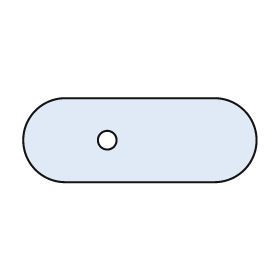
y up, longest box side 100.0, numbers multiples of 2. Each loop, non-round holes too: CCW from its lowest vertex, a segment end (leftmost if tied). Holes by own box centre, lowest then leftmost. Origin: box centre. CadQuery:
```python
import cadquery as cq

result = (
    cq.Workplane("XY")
    .moveTo(-32.0, -18.0)
    .lineTo(32.0, -18.0)
    .threePointArc((50.0, 0.0), (32.0, 18.0))
    .lineTo(-32.0, 18.0)
    .threePointArc((-50.0, 0.0), (-32.0, -18.0))
    .close()
    .moveTo(-14.0, 0.0)
    .circle(4.0)
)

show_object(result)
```